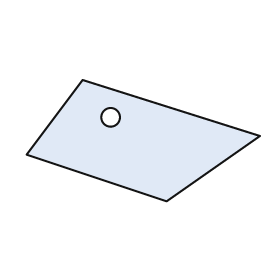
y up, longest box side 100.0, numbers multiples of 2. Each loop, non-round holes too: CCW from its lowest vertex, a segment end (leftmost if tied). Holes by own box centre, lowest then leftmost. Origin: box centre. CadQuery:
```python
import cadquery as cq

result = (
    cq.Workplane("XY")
    .moveTo(10.0, -26.0)
    .lineTo(50.0, 2.0)
    .lineTo(-26.0, 26.0)
    .lineTo(-50.0, -6.0)
    .close()
    .moveTo(-14.0, 10.0)
    .circle(4.0)
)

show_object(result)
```